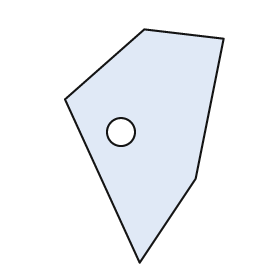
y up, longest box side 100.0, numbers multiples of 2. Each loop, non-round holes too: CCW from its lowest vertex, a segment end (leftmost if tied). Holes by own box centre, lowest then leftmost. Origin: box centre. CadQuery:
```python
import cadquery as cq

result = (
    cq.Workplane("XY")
    .moveTo(-2.0, -50.0)
    .lineTo(22.0, -14.0)
    .lineTo(34.0, 46.0)
    .lineTo(0.0, 50.0)
    .lineTo(-34.0, 20.0)
    .close()
    .moveTo(-10.0, 6.0)
    .circle(6.0)
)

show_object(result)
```